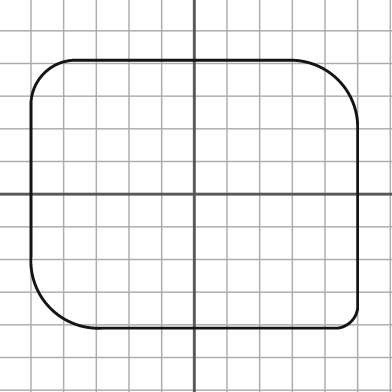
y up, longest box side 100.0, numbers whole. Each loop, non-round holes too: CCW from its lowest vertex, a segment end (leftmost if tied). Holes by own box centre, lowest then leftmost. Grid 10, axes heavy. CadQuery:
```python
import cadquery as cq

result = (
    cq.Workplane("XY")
    .moveTo(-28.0, -41.0)
    .lineTo(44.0, -41.0)
    .threePointArc((48.0, -39.0), (50.0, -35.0))
    .lineTo(50.0, 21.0)
    .threePointArc((44.0, 35.0), (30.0, 41.0))
    .lineTo(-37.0, 41.0)
    .threePointArc((-46.0, 37.0), (-50.0, 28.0))
    .lineTo(-50.0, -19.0)
    .threePointArc((-44.0, -35.0), (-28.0, -41.0))
    .close()
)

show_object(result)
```